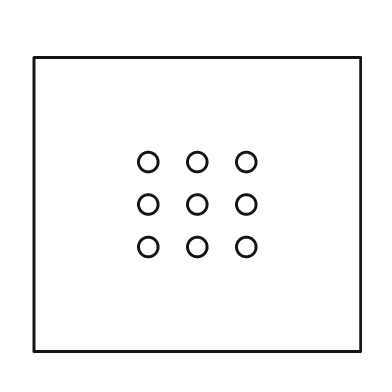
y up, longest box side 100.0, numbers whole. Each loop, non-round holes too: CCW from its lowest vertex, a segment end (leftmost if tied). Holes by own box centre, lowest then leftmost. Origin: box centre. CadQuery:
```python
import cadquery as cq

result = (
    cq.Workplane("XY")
    .moveTo(-50.0, -45.0)
    .lineTo(50.0, -45.0)
    .lineTo(50.0, 45.0)
    .lineTo(-50.0, 45.0)
    .close()
    .moveTo(-15.0, -13.0)
    .circle(3.0)
    .moveTo(0.0, -13.0)
    .circle(3.0)
    .moveTo(15.0, -13.0)
    .circle(3.0)
    .moveTo(-15.0, 0.0)
    .circle(3.0)
    .moveTo(0.0, 0.0)
    .circle(3.0)
    .moveTo(15.0, 0.0)
    .circle(3.0)
    .moveTo(-15.0, 13.0)
    .circle(3.0)
    .moveTo(0.0, 13.0)
    .circle(3.0)
    .moveTo(15.0, 13.0)
    .circle(3.0)
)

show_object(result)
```